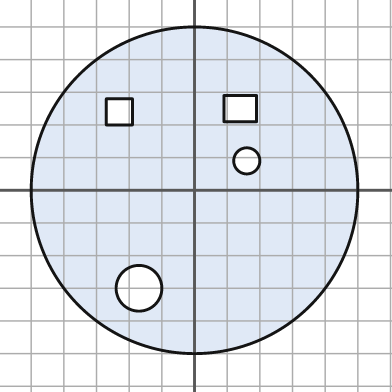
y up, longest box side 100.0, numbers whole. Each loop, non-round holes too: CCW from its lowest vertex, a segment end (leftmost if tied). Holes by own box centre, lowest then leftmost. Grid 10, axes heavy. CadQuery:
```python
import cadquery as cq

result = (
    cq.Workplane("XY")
    .moveTo(0.0, 0.0)
    .circle(50.0)
    .moveTo(-17.0, -30.0)
    .circle(7.0)
    .moveTo(16.0, 9.0)
    .circle(4.0)
    .moveTo(-27.0, 20.0)
    .lineTo(-19.0, 20.0)
    .lineTo(-19.0, 28.0)
    .lineTo(-27.0, 28.0)
    .close()
    .moveTo(9.0, 21.0)
    .lineTo(19.0, 21.0)
    .lineTo(19.0, 29.0)
    .lineTo(9.0, 29.0)
    .close()
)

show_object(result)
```